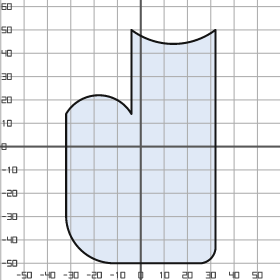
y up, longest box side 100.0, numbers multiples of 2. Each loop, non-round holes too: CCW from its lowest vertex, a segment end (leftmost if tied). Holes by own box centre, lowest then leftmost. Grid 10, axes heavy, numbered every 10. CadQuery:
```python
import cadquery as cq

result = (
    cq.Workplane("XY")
    .moveTo(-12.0, -50.0)
    .lineTo(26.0, -50.0)
    .threePointArc((30.0, -48.0), (32.0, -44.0))
    .lineTo(32.0, 50.0)
    .threePointArc((14.0, 44.0), (-4.0, 50.0))
    .lineTo(-4.0, 14.0)
    .threePointArc((-18.0, 22.0), (-32.0, 14.0))
    .lineTo(-32.0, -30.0)
    .threePointArc((-26.0, -44.0), (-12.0, -50.0))
    .close()
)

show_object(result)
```